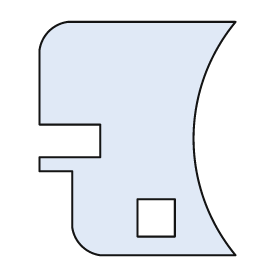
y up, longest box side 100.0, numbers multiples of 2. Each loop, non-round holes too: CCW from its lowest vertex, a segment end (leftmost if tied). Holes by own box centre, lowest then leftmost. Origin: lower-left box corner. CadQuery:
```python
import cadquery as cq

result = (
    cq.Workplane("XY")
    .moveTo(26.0, 0.0)
    .lineTo(84.0, 0.0)
    .threePointArc((66.0, 50.0), (84.0, 100.0))
    .lineTo(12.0, 100.0)
    .threePointArc((4.0, 96.0), (0.0, 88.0))
    .lineTo(0.0, 56.0)
    .lineTo(26.0, 56.0)
    .lineTo(26.0, 42.0)
    .lineTo(0.0, 42.0)
    .lineTo(0.0, 36.0)
    .lineTo(14.0, 36.0)
    .lineTo(14.0, 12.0)
    .threePointArc((18.0, 4.0), (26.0, 0.0))
    .close()
    .moveTo(42.0, 8.0)
    .lineTo(58.0, 8.0)
    .lineTo(58.0, 24.0)
    .lineTo(42.0, 24.0)
    .close()
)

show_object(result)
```